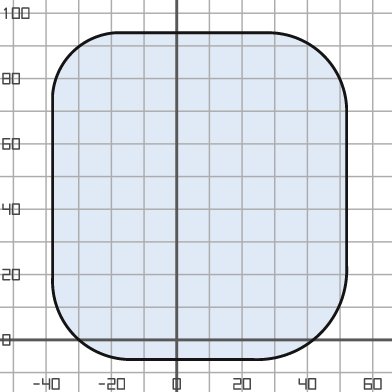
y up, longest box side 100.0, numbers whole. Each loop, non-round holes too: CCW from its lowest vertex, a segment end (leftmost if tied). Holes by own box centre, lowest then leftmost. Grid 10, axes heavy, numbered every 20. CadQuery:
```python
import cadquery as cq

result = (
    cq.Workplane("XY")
    .moveTo(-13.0, -6.0)
    .lineTo(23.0, -6.0)
    .threePointArc((44.0, 2.0), (52.0, 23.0))
    .lineTo(52.0, 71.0)
    .threePointArc((45.0, 87.0), (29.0, 94.0))
    .lineTo(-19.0, 94.0)
    .threePointArc((-32.0, 88.0), (-38.0, 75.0))
    .lineTo(-38.0, 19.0)
    .threePointArc((-31.0, 1.0), (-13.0, -6.0))
    .close()
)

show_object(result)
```